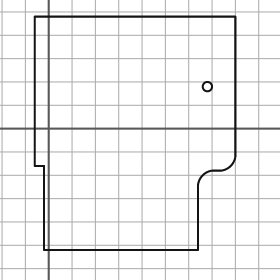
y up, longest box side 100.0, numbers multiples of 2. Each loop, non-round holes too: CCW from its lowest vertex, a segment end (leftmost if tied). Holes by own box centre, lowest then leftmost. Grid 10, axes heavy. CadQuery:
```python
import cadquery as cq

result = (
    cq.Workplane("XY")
    .moveTo(-2.0, -52.0)
    .lineTo(64.0, -52.0)
    .lineTo(64.0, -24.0)
    .threePointArc((66.0, -20.0), (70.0, -18.0))
    .lineTo(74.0, -18.0)
    .threePointArc((78.0, -16.0), (80.0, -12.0))
    .lineTo(80.0, 48.0)
    .lineTo(-6.0, 48.0)
    .lineTo(-6.0, -16.0)
    .lineTo(-2.0, -16.0)
    .close()
    .moveTo(68.0, 18.0)
    .circle(2.0)
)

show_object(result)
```